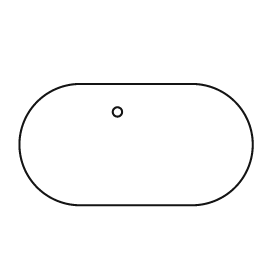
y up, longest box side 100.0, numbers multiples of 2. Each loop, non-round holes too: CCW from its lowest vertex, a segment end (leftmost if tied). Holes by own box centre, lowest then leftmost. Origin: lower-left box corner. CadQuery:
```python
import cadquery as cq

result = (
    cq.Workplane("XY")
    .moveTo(26.0, 0.0)
    .lineTo(74.0, 0.0)
    .threePointArc((100.0, 26.0), (74.0, 52.0))
    .lineTo(26.0, 52.0)
    .threePointArc((0.0, 26.0), (26.0, 0.0))
    .close()
    .moveTo(42.0, 40.0)
    .circle(2.0)
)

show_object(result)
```